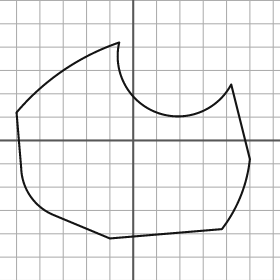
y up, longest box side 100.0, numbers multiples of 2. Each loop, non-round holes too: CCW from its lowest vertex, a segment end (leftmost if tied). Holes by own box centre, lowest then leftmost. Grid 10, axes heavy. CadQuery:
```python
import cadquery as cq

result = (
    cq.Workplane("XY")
    .moveTo(-10.0, -42.0)
    .lineTo(38.0, -38.0)
    .threePointArc((46.0, -24.0), (50.0, -8.0))
    .lineTo(42.0, 24.0)
    .threePointArc((10.0, 12.0), (-6.0, 42.0))
    .threePointArc((-30.0, 30.0), (-50.0, 12.0))
    .lineTo(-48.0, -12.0)
    .threePointArc((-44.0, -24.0), (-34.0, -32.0))
    .close()
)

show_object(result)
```